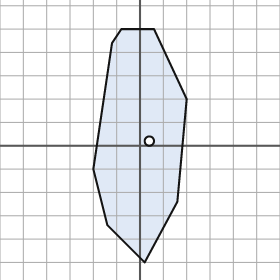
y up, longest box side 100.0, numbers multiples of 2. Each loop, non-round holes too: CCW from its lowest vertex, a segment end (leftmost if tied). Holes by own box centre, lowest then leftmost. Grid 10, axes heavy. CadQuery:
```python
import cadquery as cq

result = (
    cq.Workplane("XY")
    .moveTo(2.0, -50.0)
    .lineTo(16.0, -24.0)
    .lineTo(20.0, 20.0)
    .lineTo(6.0, 50.0)
    .lineTo(-8.0, 50.0)
    .lineTo(-12.0, 44.0)
    .lineTo(-20.0, -10.0)
    .lineTo(-14.0, -34.0)
    .close()
    .moveTo(4.0, 2.0)
    .circle(2.0)
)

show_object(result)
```